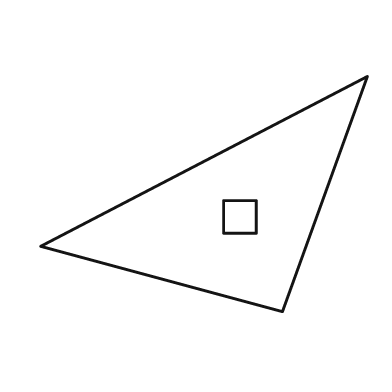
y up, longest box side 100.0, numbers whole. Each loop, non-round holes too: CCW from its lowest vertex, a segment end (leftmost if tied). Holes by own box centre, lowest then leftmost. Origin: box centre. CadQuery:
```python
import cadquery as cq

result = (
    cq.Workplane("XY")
    .moveTo(24.0, -36.0)
    .lineTo(50.0, 36.0)
    .lineTo(-50.0, -16.0)
    .close()
    .moveTo(6.0, -12.0)
    .lineTo(16.0, -12.0)
    .lineTo(16.0, -2.0)
    .lineTo(6.0, -2.0)
    .close()
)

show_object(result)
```